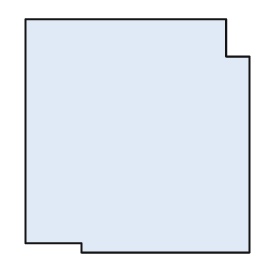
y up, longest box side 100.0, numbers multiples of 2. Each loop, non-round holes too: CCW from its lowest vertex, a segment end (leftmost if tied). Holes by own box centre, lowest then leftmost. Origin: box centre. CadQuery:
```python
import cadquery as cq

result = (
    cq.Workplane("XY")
    .moveTo(-24.0, -50.0)
    .lineTo(48.0, -50.0)
    .lineTo(48.0, 34.0)
    .lineTo(38.0, 34.0)
    .lineTo(38.0, 50.0)
    .lineTo(-48.0, 50.0)
    .lineTo(-48.0, -46.0)
    .lineTo(-24.0, -46.0)
    .close()
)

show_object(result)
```